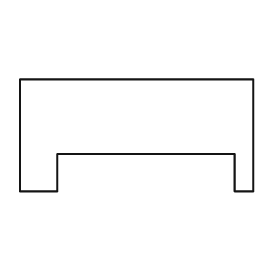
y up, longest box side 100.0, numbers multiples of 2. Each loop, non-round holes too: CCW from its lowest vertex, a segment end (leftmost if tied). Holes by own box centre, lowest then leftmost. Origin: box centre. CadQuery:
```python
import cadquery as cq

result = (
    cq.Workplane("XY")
    .moveTo(-50.0, -24.0)
    .lineTo(-34.0, -24.0)
    .lineTo(-34.0, -8.0)
    .lineTo(42.0, -8.0)
    .lineTo(42.0, -24.0)
    .lineTo(50.0, -24.0)
    .lineTo(50.0, 24.0)
    .lineTo(-50.0, 24.0)
    .close()
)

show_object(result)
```